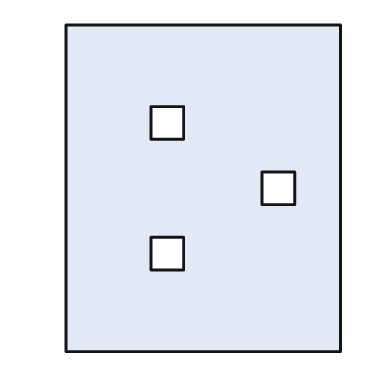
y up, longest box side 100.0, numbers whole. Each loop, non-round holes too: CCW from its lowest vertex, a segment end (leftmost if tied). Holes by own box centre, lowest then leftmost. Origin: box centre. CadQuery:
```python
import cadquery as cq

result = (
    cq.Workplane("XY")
    .moveTo(-42.0, -50.0)
    .lineTo(42.0, -50.0)
    .lineTo(42.0, 50.0)
    .lineTo(-42.0, 50.0)
    .close()
    .moveTo(-16.0, -25.0)
    .lineTo(-6.0, -25.0)
    .lineTo(-6.0, -15.0)
    .lineTo(-16.0, -15.0)
    .close()
    .moveTo(18.0, -5.0)
    .lineTo(28.0, -5.0)
    .lineTo(28.0, 5.0)
    .lineTo(18.0, 5.0)
    .close()
    .moveTo(-16.0, 15.0)
    .lineTo(-6.0, 15.0)
    .lineTo(-6.0, 25.0)
    .lineTo(-16.0, 25.0)
    .close()
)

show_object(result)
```